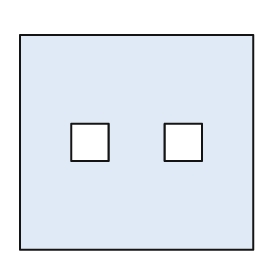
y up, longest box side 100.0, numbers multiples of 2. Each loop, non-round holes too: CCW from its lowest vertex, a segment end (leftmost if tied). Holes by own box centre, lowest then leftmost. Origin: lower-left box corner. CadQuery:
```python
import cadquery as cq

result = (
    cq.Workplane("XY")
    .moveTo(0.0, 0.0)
    .lineTo(100.0, 0.0)
    .lineTo(100.0, 92.0)
    .lineTo(0.0, 92.0)
    .close()
    .moveTo(22.0, 38.0)
    .lineTo(38.0, 38.0)
    .lineTo(38.0, 54.0)
    .lineTo(22.0, 54.0)
    .close()
    .moveTo(62.0, 38.0)
    .lineTo(78.0, 38.0)
    .lineTo(78.0, 54.0)
    .lineTo(62.0, 54.0)
    .close()
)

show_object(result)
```